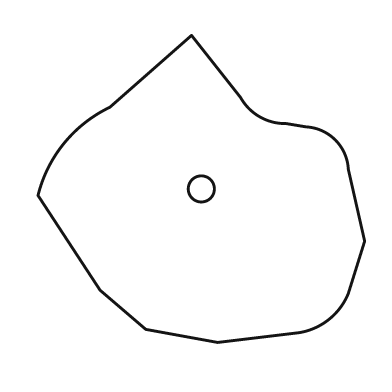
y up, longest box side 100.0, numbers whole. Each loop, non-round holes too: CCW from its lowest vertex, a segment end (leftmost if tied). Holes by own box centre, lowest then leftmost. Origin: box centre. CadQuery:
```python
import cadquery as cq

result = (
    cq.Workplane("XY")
    .moveTo(5.0, -47.0)
    .lineTo(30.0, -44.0)
    .threePointArc((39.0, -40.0), (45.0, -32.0))
    .lineTo(50.0, -16.0)
    .lineTo(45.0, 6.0)
    .threePointArc((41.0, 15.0), (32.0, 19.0))
    .lineTo(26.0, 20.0)
    .threePointArc((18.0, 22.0), (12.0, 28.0))
    .lineTo(-3.0, 47.0)
    .lineTo(-28.0, 25.0)
    .threePointArc((-42.0, 14.0), (-50.0, -2.0))
    .lineTo(-31.0, -31.0)
    .lineTo(-17.0, -43.0)
    .close()
    .moveTo(0.0, 0.0)
    .circle(4.0)
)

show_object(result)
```